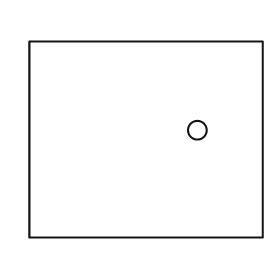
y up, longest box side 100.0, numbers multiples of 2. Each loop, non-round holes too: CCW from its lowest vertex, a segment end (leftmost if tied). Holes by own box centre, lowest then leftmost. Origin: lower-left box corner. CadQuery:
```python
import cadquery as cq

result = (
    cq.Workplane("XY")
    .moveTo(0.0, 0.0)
    .lineTo(100.0, 0.0)
    .lineTo(100.0, 84.0)
    .lineTo(0.0, 84.0)
    .close()
    .moveTo(72.0, 46.0)
    .circle(4.0)
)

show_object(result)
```